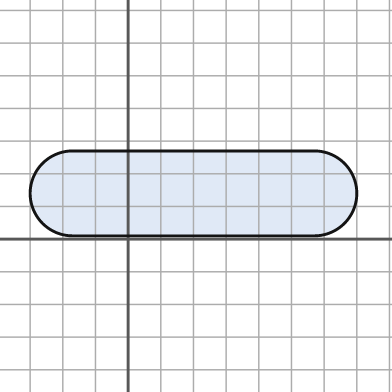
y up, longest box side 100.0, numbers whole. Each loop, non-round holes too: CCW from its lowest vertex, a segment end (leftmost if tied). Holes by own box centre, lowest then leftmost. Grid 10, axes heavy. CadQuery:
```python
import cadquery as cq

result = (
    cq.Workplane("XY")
    .moveTo(-17.0, 1.0)
    .lineTo(57.0, 1.0)
    .threePointArc((70.0, 14.0), (57.0, 27.0))
    .lineTo(-17.0, 27.0)
    .threePointArc((-30.0, 14.0), (-17.0, 1.0))
    .close()
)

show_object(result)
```